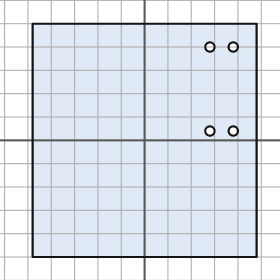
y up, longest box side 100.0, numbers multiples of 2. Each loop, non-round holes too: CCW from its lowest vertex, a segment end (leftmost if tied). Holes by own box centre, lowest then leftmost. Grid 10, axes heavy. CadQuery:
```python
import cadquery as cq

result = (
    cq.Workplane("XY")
    .moveTo(-48.0, -50.0)
    .lineTo(48.0, -50.0)
    .lineTo(48.0, 50.0)
    .lineTo(-48.0, 50.0)
    .close()
    .moveTo(28.0, 4.0)
    .circle(2.0)
    .moveTo(38.0, 4.0)
    .circle(2.0)
    .moveTo(28.0, 40.0)
    .circle(2.0)
    .moveTo(38.0, 40.0)
    .circle(2.0)
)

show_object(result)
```